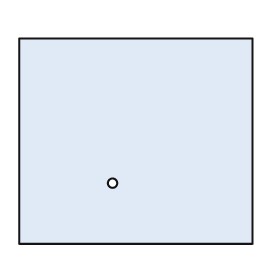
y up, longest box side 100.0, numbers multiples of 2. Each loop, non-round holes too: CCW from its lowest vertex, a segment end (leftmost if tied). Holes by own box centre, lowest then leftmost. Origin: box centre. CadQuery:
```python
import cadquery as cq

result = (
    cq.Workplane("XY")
    .moveTo(-50.0, -44.0)
    .lineTo(50.0, -44.0)
    .lineTo(50.0, 44.0)
    .lineTo(-50.0, 44.0)
    .close()
    .moveTo(-10.0, -18.0)
    .circle(2.0)
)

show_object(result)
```